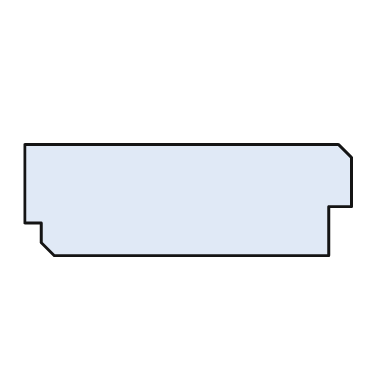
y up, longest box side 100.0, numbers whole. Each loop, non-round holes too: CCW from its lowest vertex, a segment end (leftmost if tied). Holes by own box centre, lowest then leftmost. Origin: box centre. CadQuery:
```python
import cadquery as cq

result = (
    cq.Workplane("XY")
    .moveTo(-41.0, -17.0)
    .lineTo(43.0, -17.0)
    .lineTo(43.0, -2.0)
    .lineTo(50.0, -2.0)
    .lineTo(50.0, 13.0)
    .lineTo(46.0, 17.0)
    .lineTo(-50.0, 17.0)
    .lineTo(-50.0, -7.0)
    .lineTo(-45.0, -7.0)
    .lineTo(-45.0, -13.0)
    .close()
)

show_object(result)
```